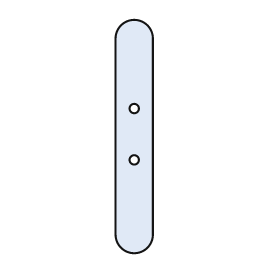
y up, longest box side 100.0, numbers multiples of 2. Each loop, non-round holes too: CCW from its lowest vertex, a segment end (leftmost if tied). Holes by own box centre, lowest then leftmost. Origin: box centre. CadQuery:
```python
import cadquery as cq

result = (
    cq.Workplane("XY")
    .moveTo(-8.0, -42.0)
    .threePointArc((0.0, -50.0), (8.0, -42.0))
    .lineTo(8.0, 42.0)
    .threePointArc((0.0, 50.0), (-8.0, 42.0))
    .close()
    .moveTo(0.0, -10.0)
    .circle(2.0)
    .moveTo(0.0, 12.0)
    .circle(2.0)
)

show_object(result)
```